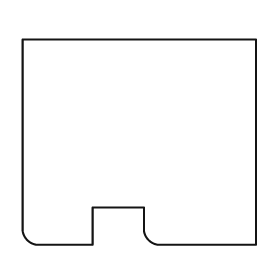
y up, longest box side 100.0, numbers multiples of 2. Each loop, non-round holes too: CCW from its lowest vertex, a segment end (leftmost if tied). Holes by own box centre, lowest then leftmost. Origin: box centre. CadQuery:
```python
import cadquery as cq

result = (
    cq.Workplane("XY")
    .moveTo(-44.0, -44.0)
    .lineTo(-20.0, -44.0)
    .lineTo(-20.0, -28.0)
    .lineTo(2.0, -28.0)
    .lineTo(2.0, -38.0)
    .threePointArc((4.0, -42.0), (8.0, -44.0))
    .lineTo(50.0, -44.0)
    .lineTo(50.0, 44.0)
    .lineTo(-50.0, 44.0)
    .lineTo(-50.0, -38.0)
    .threePointArc((-48.0, -42.0), (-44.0, -44.0))
    .close()
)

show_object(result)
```